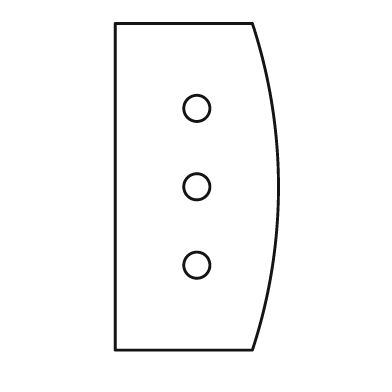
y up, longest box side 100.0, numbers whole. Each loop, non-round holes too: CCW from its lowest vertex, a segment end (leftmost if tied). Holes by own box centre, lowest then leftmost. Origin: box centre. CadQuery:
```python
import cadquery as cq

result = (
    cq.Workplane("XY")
    .moveTo(-25.0, -50.0)
    .lineTo(17.0, -50.0)
    .threePointArc((25.0, 0.0), (17.0, 50.0))
    .lineTo(-25.0, 50.0)
    .close()
    .moveTo(0.0, -24.0)
    .circle(4.0)
    .moveTo(0.0, 0.0)
    .circle(4.0)
    .moveTo(0.0, 24.0)
    .circle(4.0)
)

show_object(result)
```